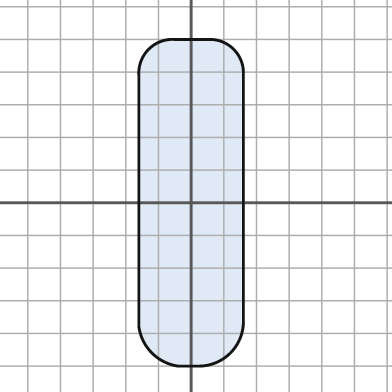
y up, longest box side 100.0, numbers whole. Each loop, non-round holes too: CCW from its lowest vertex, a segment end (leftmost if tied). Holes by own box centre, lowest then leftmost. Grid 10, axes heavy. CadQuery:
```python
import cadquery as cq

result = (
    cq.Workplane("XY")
    .moveTo(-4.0, -50.0)
    .lineTo(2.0, -50.0)
    .threePointArc((12.0, -46.0), (16.0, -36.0))
    .lineTo(16.0, 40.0)
    .threePointArc((13.0, 47.0), (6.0, 50.0))
    .lineTo(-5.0, 50.0)
    .threePointArc((-13.0, 47.0), (-16.0, 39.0))
    .lineTo(-16.0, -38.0)
    .threePointArc((-12.0, -46.0), (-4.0, -50.0))
    .close()
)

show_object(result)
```